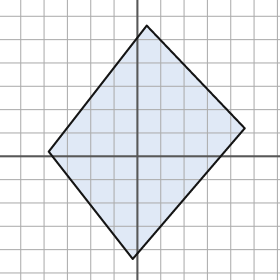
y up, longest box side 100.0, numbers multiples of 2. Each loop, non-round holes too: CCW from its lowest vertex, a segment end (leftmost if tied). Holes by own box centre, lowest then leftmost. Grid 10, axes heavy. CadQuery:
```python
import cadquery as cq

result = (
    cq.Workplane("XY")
    .moveTo(-2.0, -44.0)
    .lineTo(46.0, 12.0)
    .lineTo(4.0, 56.0)
    .lineTo(-38.0, 2.0)
    .close()
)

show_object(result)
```